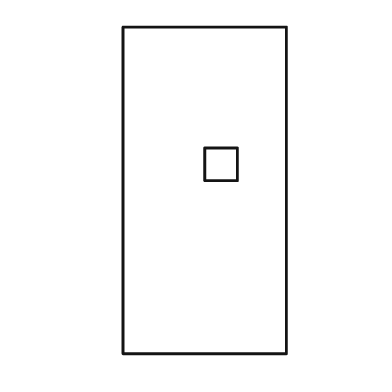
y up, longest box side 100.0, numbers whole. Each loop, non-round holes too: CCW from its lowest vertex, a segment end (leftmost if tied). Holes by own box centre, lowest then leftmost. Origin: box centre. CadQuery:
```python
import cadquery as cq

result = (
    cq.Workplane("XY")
    .moveTo(-25.0, -50.0)
    .lineTo(25.0, -50.0)
    .lineTo(25.0, 50.0)
    .lineTo(-25.0, 50.0)
    .close()
    .moveTo(0.0, 3.0)
    .lineTo(10.0, 3.0)
    .lineTo(10.0, 13.0)
    .lineTo(0.0, 13.0)
    .close()
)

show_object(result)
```